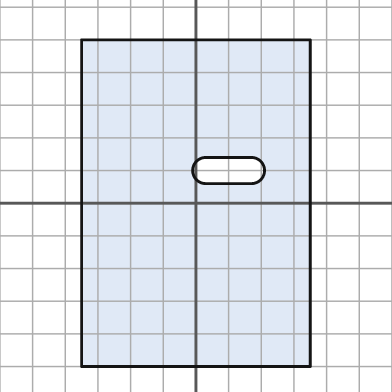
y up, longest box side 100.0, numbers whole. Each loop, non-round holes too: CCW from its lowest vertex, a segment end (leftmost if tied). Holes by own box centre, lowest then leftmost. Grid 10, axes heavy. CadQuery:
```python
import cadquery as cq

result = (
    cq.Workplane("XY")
    .moveTo(-35.0, -50.0)
    .lineTo(35.0, -50.0)
    .lineTo(35.0, 50.0)
    .lineTo(-35.0, 50.0)
    .close()
    .moveTo(3.0, 6.0)
    .lineTo(17.0, 6.0)
    .threePointArc((21.0, 10.0), (17.0, 14.0))
    .lineTo(3.0, 14.0)
    .threePointArc((-1.0, 10.0), (3.0, 6.0))
    .close()
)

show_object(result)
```